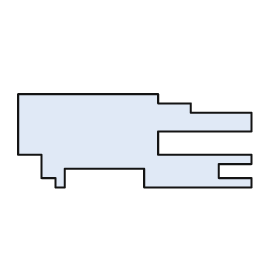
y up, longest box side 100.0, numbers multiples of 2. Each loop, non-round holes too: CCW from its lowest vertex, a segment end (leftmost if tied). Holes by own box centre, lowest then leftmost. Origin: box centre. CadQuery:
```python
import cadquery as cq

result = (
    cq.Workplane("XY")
    .moveTo(-34.0, -20.0)
    .lineTo(-30.0, -20.0)
    .lineTo(-30.0, -12.0)
    .lineTo(4.0, -12.0)
    .lineTo(4.0, -20.0)
    .lineTo(50.0, -20.0)
    .lineTo(50.0, -16.0)
    .lineTo(36.0, -16.0)
    .lineTo(36.0, -10.0)
    .lineTo(50.0, -10.0)
    .lineTo(50.0, -6.0)
    .lineTo(10.0, -6.0)
    .lineTo(10.0, 4.0)
    .lineTo(50.0, 4.0)
    .lineTo(50.0, 12.0)
    .lineTo(24.0, 12.0)
    .lineTo(24.0, 16.0)
    .lineTo(10.0, 16.0)
    .lineTo(10.0, 20.0)
    .lineTo(-50.0, 20.0)
    .lineTo(-50.0, -6.0)
    .lineTo(-40.0, -6.0)
    .lineTo(-40.0, -16.0)
    .lineTo(-34.0, -16.0)
    .close()
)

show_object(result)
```